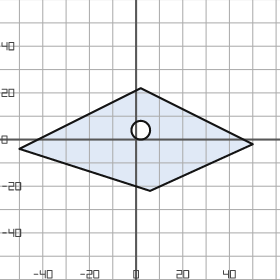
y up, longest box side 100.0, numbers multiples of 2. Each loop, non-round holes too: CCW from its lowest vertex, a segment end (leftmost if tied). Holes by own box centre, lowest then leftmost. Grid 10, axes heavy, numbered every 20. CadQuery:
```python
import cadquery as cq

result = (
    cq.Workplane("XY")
    .moveTo(6.0, -22.0)
    .lineTo(50.0, -2.0)
    .lineTo(2.0, 22.0)
    .lineTo(-50.0, -4.0)
    .close()
    .moveTo(2.0, 4.0)
    .circle(4.0)
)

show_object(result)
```